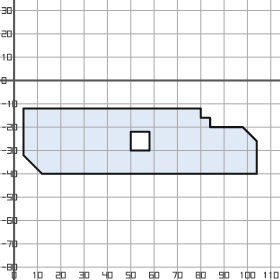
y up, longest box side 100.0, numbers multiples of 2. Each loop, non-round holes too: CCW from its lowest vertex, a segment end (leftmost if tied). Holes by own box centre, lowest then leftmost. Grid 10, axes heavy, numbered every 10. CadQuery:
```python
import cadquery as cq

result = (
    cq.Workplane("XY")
    .moveTo(12.0, -40.0)
    .lineTo(104.0, -40.0)
    .lineTo(104.0, -26.0)
    .lineTo(98.0, -20.0)
    .lineTo(84.0, -20.0)
    .lineTo(84.0, -16.0)
    .lineTo(80.0, -16.0)
    .lineTo(80.0, -12.0)
    .lineTo(4.0, -12.0)
    .lineTo(4.0, -32.0)
    .close()
    .moveTo(50.0, -30.0)
    .lineTo(58.0, -30.0)
    .lineTo(58.0, -22.0)
    .lineTo(50.0, -22.0)
    .close()
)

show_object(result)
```